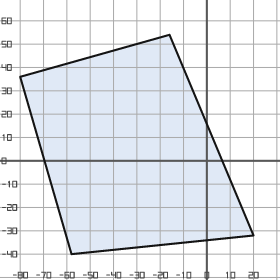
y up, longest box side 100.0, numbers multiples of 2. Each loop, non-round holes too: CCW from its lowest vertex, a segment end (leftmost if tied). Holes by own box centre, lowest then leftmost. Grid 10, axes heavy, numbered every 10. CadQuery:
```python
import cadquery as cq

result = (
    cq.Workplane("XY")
    .moveTo(-58.0, -40.0)
    .lineTo(20.0, -32.0)
    .lineTo(-16.0, 54.0)
    .lineTo(-80.0, 36.0)
    .close()
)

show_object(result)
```